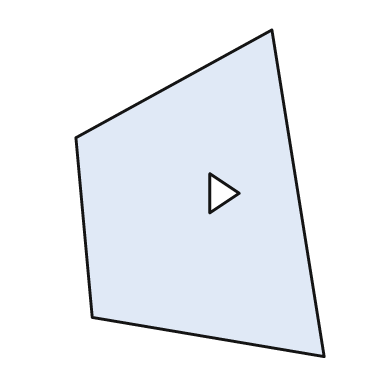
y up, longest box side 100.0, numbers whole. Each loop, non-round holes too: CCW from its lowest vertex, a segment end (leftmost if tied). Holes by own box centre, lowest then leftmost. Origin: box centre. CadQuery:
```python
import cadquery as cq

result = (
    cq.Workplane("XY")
    .moveTo(38.0, -50.0)
    .lineTo(22.0, 50.0)
    .lineTo(-38.0, 17.0)
    .lineTo(-33.0, -38.0)
    .close()
    .moveTo(3.0, -6.0)
    .lineTo(12.0, 0.0)
    .lineTo(3.0, 6.0)
    .close()
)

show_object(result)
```